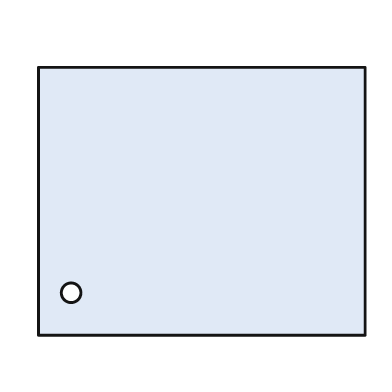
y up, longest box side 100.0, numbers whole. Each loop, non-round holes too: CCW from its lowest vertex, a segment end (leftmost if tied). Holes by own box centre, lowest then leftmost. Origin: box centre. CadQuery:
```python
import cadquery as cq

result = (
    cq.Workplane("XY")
    .moveTo(-50.0, -41.0)
    .lineTo(50.0, -41.0)
    .lineTo(50.0, 41.0)
    .lineTo(-50.0, 41.0)
    .close()
    .moveTo(-40.0, -28.0)
    .circle(3.0)
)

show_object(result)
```